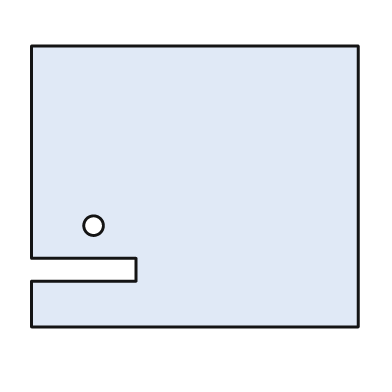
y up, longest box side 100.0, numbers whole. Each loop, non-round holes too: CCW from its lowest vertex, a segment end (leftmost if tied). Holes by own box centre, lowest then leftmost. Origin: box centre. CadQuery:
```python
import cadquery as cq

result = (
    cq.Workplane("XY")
    .moveTo(-50.0, -43.0)
    .lineTo(50.0, -43.0)
    .lineTo(50.0, 43.0)
    .lineTo(-50.0, 43.0)
    .lineTo(-50.0, -22.0)
    .lineTo(-18.0, -22.0)
    .lineTo(-18.0, -29.0)
    .lineTo(-50.0, -29.0)
    .close()
    .moveTo(-31.0, -12.0)
    .circle(3.0)
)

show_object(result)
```